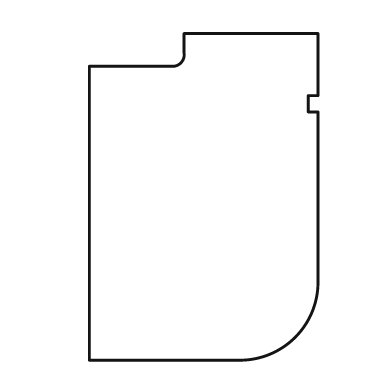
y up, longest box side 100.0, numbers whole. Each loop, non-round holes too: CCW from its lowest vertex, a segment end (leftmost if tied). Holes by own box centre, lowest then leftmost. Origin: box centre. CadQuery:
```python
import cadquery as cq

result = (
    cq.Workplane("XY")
    .moveTo(-35.0, -50.0)
    .lineTo(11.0, -50.0)
    .threePointArc((28.0, -43.0), (35.0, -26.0))
    .lineTo(35.0, 26.0)
    .lineTo(32.0, 26.0)
    .lineTo(32.0, 31.0)
    .lineTo(35.0, 31.0)
    .lineTo(35.0, 50.0)
    .lineTo(-6.0, 50.0)
    .lineTo(-6.0, 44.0)
    .threePointArc((-7.0, 41.0), (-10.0, 40.0))
    .lineTo(-35.0, 40.0)
    .close()
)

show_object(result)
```